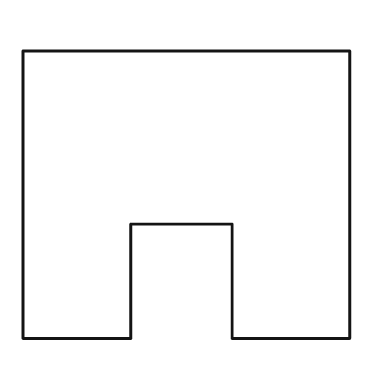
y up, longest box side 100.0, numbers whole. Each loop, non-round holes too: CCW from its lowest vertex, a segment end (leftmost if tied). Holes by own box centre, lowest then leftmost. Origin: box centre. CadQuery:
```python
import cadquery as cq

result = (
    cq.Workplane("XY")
    .moveTo(-50.0, -44.0)
    .lineTo(-17.0, -44.0)
    .lineTo(-17.0, -9.0)
    .lineTo(14.0, -9.0)
    .lineTo(14.0, -44.0)
    .lineTo(50.0, -44.0)
    .lineTo(50.0, 44.0)
    .lineTo(-50.0, 44.0)
    .close()
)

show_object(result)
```